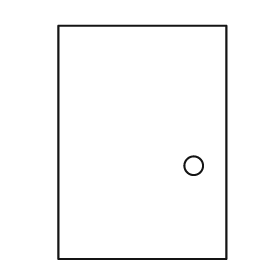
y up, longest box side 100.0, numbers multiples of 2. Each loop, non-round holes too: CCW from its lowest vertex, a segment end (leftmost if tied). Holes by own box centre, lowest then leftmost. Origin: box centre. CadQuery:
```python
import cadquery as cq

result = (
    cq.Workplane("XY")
    .moveTo(-36.0, -50.0)
    .lineTo(36.0, -50.0)
    .lineTo(36.0, 50.0)
    .lineTo(-36.0, 50.0)
    .close()
    .moveTo(22.0, -10.0)
    .circle(4.0)
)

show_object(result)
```